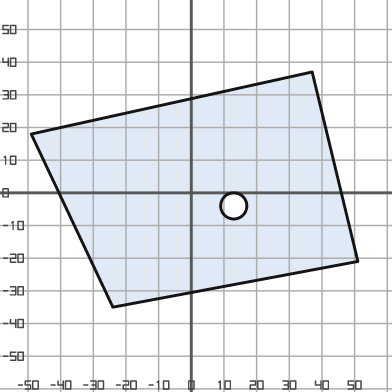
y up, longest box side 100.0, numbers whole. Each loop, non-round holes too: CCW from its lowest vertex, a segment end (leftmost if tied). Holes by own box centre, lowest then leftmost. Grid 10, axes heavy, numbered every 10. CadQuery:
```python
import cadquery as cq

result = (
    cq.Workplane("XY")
    .moveTo(-24.0, -35.0)
    .lineTo(51.0, -21.0)
    .lineTo(37.0, 37.0)
    .lineTo(-49.0, 18.0)
    .close()
    .moveTo(13.0, -4.0)
    .circle(4.0)
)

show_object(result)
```